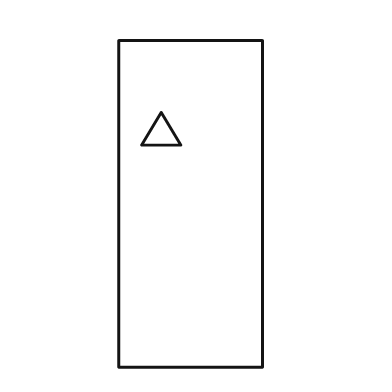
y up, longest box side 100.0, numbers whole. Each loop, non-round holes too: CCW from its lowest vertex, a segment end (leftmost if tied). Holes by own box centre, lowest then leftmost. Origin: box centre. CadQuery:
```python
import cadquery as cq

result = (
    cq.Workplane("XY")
    .moveTo(-22.0, -50.0)
    .lineTo(22.0, -50.0)
    .lineTo(22.0, 50.0)
    .lineTo(-22.0, 50.0)
    .close()
    .moveTo(-15.0, 18.0)
    .lineTo(-3.0, 18.0)
    .lineTo(-9.0, 28.0)
    .close()
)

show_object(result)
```